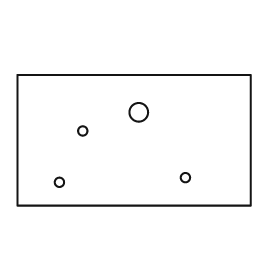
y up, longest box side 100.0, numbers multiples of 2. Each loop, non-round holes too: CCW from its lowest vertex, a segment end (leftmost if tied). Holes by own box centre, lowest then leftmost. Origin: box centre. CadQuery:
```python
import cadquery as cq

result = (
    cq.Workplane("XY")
    .moveTo(-50.0, -28.0)
    .lineTo(50.0, -28.0)
    .lineTo(50.0, 28.0)
    .lineTo(-50.0, 28.0)
    .close()
    .moveTo(-32.0, -18.0)
    .circle(2.0)
    .moveTo(22.0, -16.0)
    .circle(2.0)
    .moveTo(-22.0, 4.0)
    .circle(2.0)
    .moveTo(2.0, 12.0)
    .circle(4.0)
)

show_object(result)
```